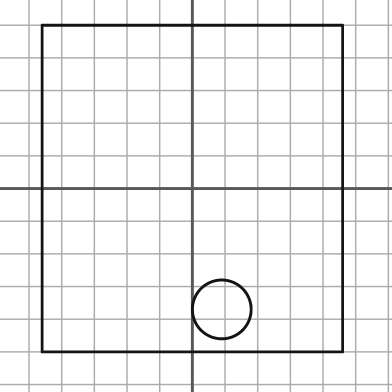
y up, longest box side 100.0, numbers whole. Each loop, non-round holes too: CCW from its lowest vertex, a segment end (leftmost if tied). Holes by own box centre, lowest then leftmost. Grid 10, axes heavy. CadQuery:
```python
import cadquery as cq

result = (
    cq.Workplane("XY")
    .moveTo(-46.0, -50.0)
    .lineTo(46.0, -50.0)
    .lineTo(46.0, 50.0)
    .lineTo(-46.0, 50.0)
    .close()
    .moveTo(9.0, -37.0)
    .circle(9.0)
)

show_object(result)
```